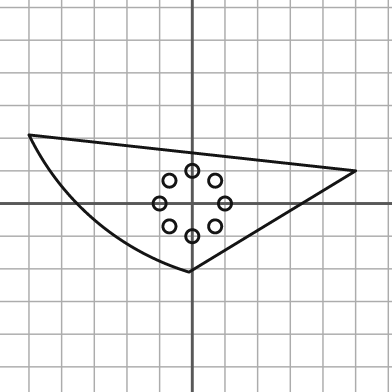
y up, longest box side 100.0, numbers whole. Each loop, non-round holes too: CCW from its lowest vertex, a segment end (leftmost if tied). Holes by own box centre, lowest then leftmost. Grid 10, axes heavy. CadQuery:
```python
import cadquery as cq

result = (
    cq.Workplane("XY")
    .moveTo(-1.0, -21.0)
    .lineTo(50.0, 10.0)
    .lineTo(-50.0, 21.0)
    .threePointArc((-30.0, -5.0), (-1.0, -21.0))
    .close()
    .moveTo(0.0, -10.0)
    .circle(2.0)
    .moveTo(-7.0, -7.0)
    .circle(2.0)
    .moveTo(7.0, -7.0)
    .circle(2.0)
    .moveTo(-10.0, 0.0)
    .circle(2.0)
    .moveTo(10.0, 0.0)
    .circle(2.0)
    .moveTo(-7.0, 7.0)
    .circle(2.0)
    .moveTo(7.0, 7.0)
    .circle(2.0)
    .moveTo(0.0, 10.0)
    .circle(2.0)
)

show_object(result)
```